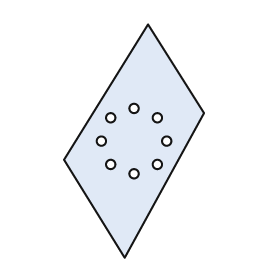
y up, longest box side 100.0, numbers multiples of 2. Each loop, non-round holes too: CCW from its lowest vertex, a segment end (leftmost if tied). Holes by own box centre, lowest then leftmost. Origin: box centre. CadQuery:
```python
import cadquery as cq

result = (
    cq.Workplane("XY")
    .moveTo(-4.0, -50.0)
    .lineTo(30.0, 12.0)
    .lineTo(6.0, 50.0)
    .lineTo(-30.0, -8.0)
    .close()
    .moveTo(0.0, -14.0)
    .circle(2.0)
    .moveTo(-10.0, -10.0)
    .circle(2.0)
    .moveTo(10.0, -10.0)
    .circle(2.0)
    .moveTo(-14.0, 0.0)
    .circle(2.0)
    .moveTo(14.0, 0.0)
    .circle(2.0)
    .moveTo(-10.0, 10.0)
    .circle(2.0)
    .moveTo(10.0, 10.0)
    .circle(2.0)
    .moveTo(0.0, 14.0)
    .circle(2.0)
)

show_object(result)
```